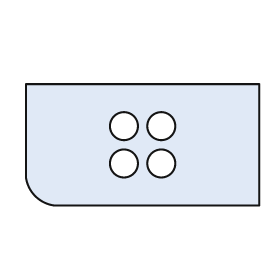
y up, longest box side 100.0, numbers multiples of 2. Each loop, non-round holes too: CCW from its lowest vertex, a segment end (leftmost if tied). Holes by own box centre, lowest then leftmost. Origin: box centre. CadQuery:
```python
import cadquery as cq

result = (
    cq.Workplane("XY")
    .moveTo(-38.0, -26.0)
    .lineTo(50.0, -26.0)
    .lineTo(50.0, 26.0)
    .lineTo(-50.0, 26.0)
    .lineTo(-50.0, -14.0)
    .threePointArc((-46.0, -22.0), (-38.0, -26.0))
    .close()
    .moveTo(-8.0, -8.0)
    .circle(6.0)
    .moveTo(8.0, -8.0)
    .circle(6.0)
    .moveTo(-8.0, 8.0)
    .circle(6.0)
    .moveTo(8.0, 8.0)
    .circle(6.0)
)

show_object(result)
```